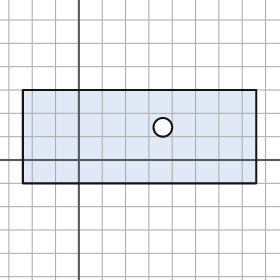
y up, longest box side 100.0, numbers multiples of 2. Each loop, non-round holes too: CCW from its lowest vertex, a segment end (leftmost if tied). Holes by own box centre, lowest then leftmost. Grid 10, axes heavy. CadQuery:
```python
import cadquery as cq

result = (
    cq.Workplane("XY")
    .moveTo(-24.0, -10.0)
    .lineTo(76.0, -10.0)
    .lineTo(76.0, 30.0)
    .lineTo(-24.0, 30.0)
    .close()
    .moveTo(36.0, 14.0)
    .circle(4.0)
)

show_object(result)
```